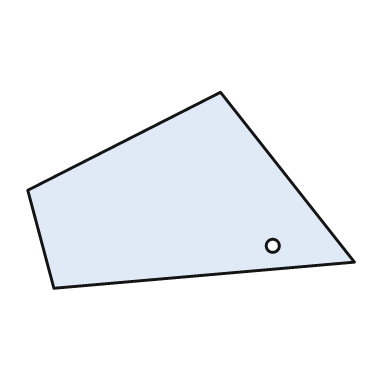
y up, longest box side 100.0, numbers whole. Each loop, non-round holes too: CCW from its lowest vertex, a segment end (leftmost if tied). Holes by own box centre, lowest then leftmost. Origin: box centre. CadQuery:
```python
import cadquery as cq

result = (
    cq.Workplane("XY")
    .moveTo(-42.0, -30.0)
    .lineTo(50.0, -22.0)
    .lineTo(9.0, 30.0)
    .lineTo(-50.0, 0.0)
    .close()
    .moveTo(25.0, -17.0)
    .circle(2.0)
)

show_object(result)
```